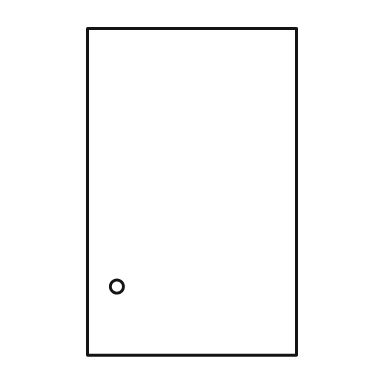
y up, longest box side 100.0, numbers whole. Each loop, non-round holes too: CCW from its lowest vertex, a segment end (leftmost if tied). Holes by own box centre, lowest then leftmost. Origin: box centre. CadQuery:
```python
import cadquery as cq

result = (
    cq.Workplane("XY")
    .moveTo(-32.0, -50.0)
    .lineTo(32.0, -50.0)
    .lineTo(32.0, 50.0)
    .lineTo(-32.0, 50.0)
    .close()
    .moveTo(-23.0, -29.0)
    .circle(2.0)
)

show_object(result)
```